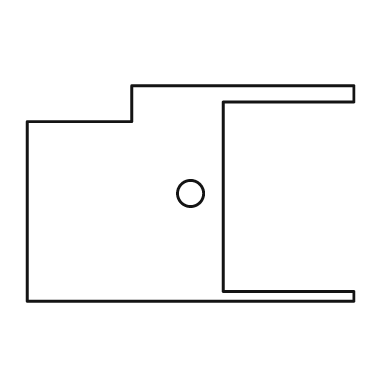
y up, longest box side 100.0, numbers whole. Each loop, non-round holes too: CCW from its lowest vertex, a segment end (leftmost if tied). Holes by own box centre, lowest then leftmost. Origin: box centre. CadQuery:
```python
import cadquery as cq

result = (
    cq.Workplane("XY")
    .moveTo(-50.0, -33.0)
    .lineTo(50.0, -33.0)
    .lineTo(50.0, -30.0)
    .lineTo(10.0, -30.0)
    .lineTo(10.0, 28.0)
    .lineTo(50.0, 28.0)
    .lineTo(50.0, 33.0)
    .lineTo(-18.0, 33.0)
    .lineTo(-18.0, 22.0)
    .lineTo(-50.0, 22.0)
    .close()
    .moveTo(0.0, 0.0)
    .circle(4.0)
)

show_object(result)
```